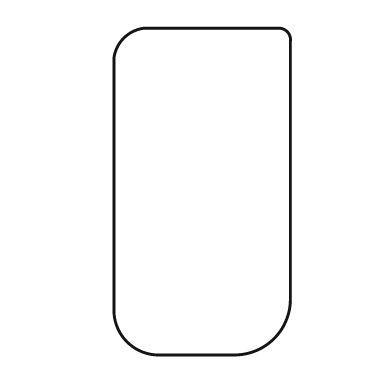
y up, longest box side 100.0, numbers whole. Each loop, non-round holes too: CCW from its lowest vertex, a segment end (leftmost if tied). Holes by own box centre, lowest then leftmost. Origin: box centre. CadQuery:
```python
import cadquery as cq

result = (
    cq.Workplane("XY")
    .moveTo(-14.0, -50.0)
    .lineTo(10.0, -50.0)
    .threePointArc((22.0, -45.0), (27.0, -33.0))
    .lineTo(27.0, 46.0)
    .threePointArc((26.0, 49.0), (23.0, 50.0))
    .lineTo(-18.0, 50.0)
    .threePointArc((-24.0, 47.0), (-27.0, 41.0))
    .lineTo(-27.0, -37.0)
    .threePointArc((-23.0, -46.0), (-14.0, -50.0))
    .close()
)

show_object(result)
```